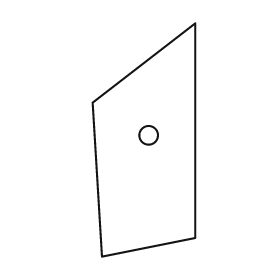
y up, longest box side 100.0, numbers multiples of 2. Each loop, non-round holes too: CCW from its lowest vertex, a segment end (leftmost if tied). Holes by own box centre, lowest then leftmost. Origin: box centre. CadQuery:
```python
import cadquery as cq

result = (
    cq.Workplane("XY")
    .moveTo(-18.0, -50.0)
    .lineTo(22.0, -42.0)
    .lineTo(22.0, 50.0)
    .lineTo(-22.0, 16.0)
    .close()
    .moveTo(2.0, 2.0)
    .circle(4.0)
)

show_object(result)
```